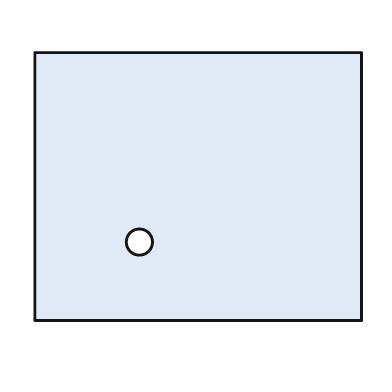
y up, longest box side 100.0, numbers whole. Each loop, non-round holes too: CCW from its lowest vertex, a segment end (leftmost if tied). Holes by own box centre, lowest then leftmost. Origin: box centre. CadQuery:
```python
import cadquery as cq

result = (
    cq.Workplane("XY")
    .moveTo(-50.0, -41.0)
    .lineTo(50.0, -41.0)
    .lineTo(50.0, 41.0)
    .lineTo(-50.0, 41.0)
    .close()
    .moveTo(-18.0, -17.0)
    .circle(4.0)
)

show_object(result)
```